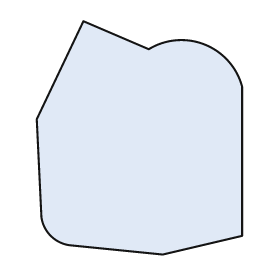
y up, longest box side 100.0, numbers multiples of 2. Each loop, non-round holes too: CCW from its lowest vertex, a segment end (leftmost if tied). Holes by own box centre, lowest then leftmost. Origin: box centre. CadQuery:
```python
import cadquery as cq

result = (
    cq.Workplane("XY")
    .moveTo(10.0, -50.0)
    .lineTo(44.0, -42.0)
    .lineTo(44.0, 22.0)
    .threePointArc((28.0, 40.0), (4.0, 38.0))
    .lineTo(-24.0, 50.0)
    .lineTo(-44.0, 8.0)
    .lineTo(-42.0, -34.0)
    .threePointArc((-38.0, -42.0), (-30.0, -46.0))
    .close()
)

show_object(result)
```